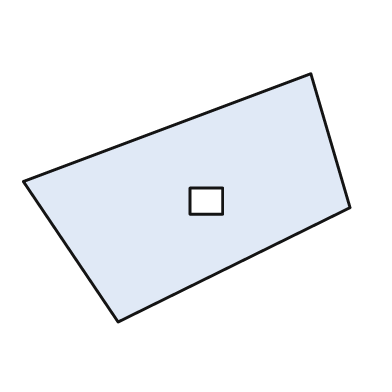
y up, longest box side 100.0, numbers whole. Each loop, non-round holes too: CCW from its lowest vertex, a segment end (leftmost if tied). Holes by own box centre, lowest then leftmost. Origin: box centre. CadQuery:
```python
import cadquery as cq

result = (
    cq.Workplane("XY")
    .moveTo(-21.0, -38.0)
    .lineTo(50.0, -3.0)
    .lineTo(38.0, 38.0)
    .lineTo(-50.0, 5.0)
    .close()
    .moveTo(1.0, -5.0)
    .lineTo(11.0, -5.0)
    .lineTo(11.0, 3.0)
    .lineTo(1.0, 3.0)
    .close()
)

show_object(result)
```